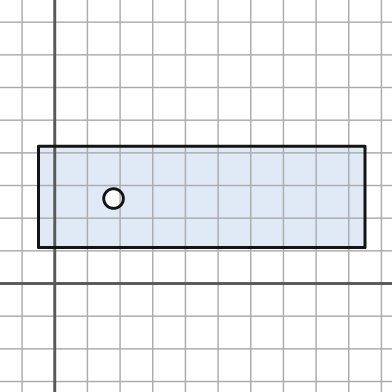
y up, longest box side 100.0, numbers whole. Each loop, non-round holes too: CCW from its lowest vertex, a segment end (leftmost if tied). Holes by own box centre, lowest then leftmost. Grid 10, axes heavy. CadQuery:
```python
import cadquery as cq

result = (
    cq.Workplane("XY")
    .moveTo(-5.0, 11.0)
    .lineTo(95.0, 11.0)
    .lineTo(95.0, 42.0)
    .lineTo(-5.0, 42.0)
    .close()
    .moveTo(18.0, 26.0)
    .circle(3.0)
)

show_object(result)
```